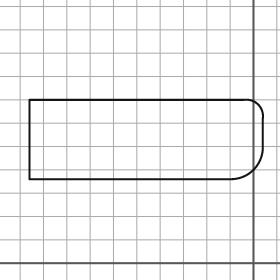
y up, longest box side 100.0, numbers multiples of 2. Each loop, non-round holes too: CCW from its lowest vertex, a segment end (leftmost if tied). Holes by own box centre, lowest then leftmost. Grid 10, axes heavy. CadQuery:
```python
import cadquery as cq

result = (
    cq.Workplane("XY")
    .moveTo(-96.0, 36.0)
    .lineTo(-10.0, 36.0)
    .threePointArc((0.0, 40.0), (4.0, 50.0))
    .lineTo(4.0, 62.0)
    .threePointArc((2.0, 68.0), (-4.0, 70.0))
    .lineTo(-96.0, 70.0)
    .close()
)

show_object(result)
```